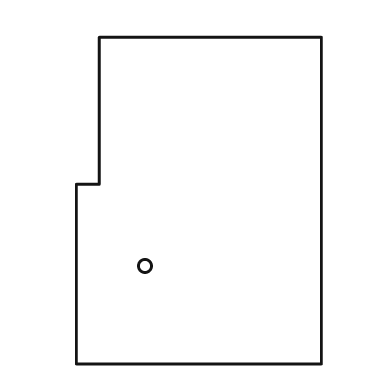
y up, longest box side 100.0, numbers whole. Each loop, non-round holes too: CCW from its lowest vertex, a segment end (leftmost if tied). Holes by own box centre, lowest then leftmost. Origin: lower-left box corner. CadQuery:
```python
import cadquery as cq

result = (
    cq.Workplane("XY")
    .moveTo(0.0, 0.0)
    .lineTo(75.0, 0.0)
    .lineTo(75.0, 100.0)
    .lineTo(7.0, 100.0)
    .lineTo(7.0, 55.0)
    .lineTo(0.0, 55.0)
    .close()
    .moveTo(21.0, 30.0)
    .circle(2.0)
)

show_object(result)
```